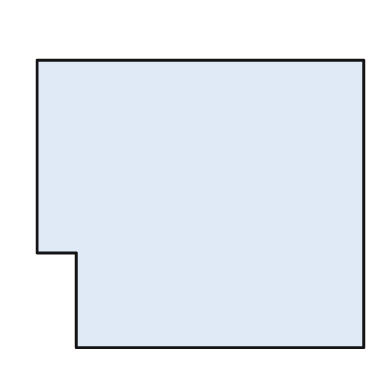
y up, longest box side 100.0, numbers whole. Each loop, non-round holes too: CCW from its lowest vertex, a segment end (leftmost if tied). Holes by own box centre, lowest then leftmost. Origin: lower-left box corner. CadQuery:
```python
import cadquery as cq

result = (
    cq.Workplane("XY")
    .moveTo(12.0, 0.0)
    .lineTo(100.0, 0.0)
    .lineTo(100.0, 88.0)
    .lineTo(0.0, 88.0)
    .lineTo(0.0, 29.0)
    .lineTo(12.0, 29.0)
    .close()
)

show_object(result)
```